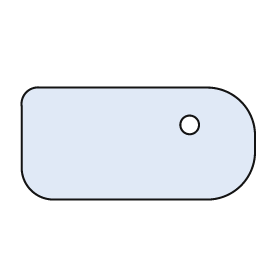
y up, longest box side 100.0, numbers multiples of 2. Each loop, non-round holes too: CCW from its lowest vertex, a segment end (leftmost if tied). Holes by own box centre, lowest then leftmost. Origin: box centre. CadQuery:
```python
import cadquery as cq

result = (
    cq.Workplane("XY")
    .moveTo(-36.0, -24.0)
    .lineTo(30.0, -24.0)
    .threePointArc((44.0, -18.0), (50.0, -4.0))
    .lineTo(50.0, 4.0)
    .threePointArc((44.0, 18.0), (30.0, 24.0))
    .lineTo(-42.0, 24.0)
    .threePointArc((-48.0, 22.0), (-50.0, 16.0))
    .lineTo(-50.0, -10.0)
    .threePointArc((-46.0, -20.0), (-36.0, -24.0))
    .close()
    .moveTo(22.0, 8.0)
    .circle(4.0)
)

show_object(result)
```